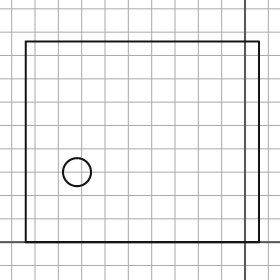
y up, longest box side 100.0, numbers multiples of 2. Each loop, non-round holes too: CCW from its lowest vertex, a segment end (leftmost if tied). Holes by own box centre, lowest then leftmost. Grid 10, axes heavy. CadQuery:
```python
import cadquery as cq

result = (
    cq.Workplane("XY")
    .moveTo(-94.0, 0.0)
    .lineTo(6.0, 0.0)
    .lineTo(6.0, 86.0)
    .lineTo(-94.0, 86.0)
    .close()
    .moveTo(-72.0, 30.0)
    .circle(6.0)
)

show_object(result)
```